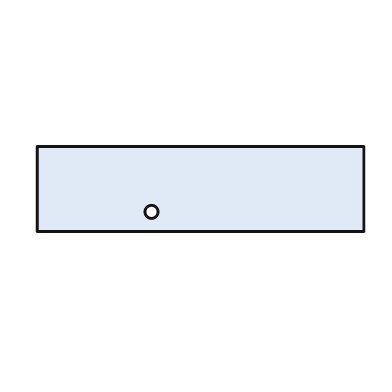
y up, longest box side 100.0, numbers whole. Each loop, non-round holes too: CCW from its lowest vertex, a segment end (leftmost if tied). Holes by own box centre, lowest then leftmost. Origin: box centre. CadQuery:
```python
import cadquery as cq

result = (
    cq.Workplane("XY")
    .moveTo(-50.0, -13.0)
    .lineTo(50.0, -13.0)
    .lineTo(50.0, 13.0)
    .lineTo(-50.0, 13.0)
    .close()
    .moveTo(-15.0, -7.0)
    .circle(2.0)
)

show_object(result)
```